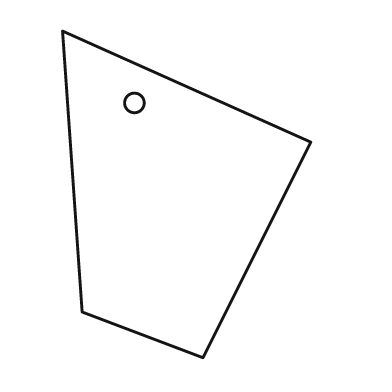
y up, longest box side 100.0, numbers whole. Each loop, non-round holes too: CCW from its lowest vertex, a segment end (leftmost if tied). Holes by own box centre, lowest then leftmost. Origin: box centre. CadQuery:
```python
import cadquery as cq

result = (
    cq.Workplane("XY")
    .moveTo(5.0, -50.0)
    .lineTo(38.0, 16.0)
    .lineTo(-38.0, 50.0)
    .lineTo(-32.0, -36.0)
    .close()
    .moveTo(-16.0, 28.0)
    .circle(3.0)
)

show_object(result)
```